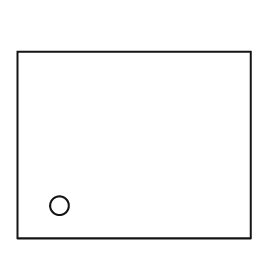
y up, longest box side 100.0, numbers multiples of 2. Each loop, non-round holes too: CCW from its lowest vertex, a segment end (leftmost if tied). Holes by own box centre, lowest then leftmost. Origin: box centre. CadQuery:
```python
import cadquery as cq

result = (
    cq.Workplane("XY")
    .moveTo(-50.0, -40.0)
    .lineTo(50.0, -40.0)
    .lineTo(50.0, 40.0)
    .lineTo(-50.0, 40.0)
    .close()
    .moveTo(-32.0, -26.0)
    .circle(4.0)
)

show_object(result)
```